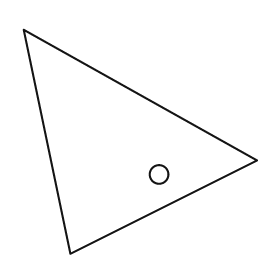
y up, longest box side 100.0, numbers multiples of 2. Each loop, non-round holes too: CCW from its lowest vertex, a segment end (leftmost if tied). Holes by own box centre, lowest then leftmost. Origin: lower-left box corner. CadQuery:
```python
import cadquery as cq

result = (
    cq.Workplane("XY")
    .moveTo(20.0, 0.0)
    .lineTo(100.0, 40.0)
    .lineTo(0.0, 96.0)
    .close()
    .moveTo(58.0, 34.0)
    .circle(4.0)
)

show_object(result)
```